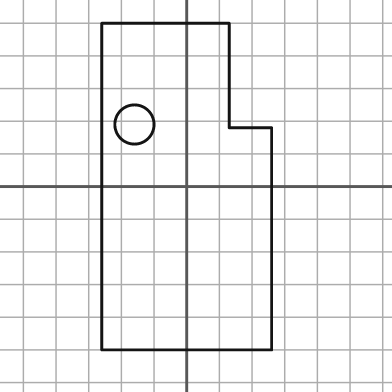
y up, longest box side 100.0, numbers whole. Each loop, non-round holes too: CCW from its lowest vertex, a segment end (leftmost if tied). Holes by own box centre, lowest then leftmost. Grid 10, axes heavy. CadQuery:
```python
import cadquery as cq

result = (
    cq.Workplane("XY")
    .moveTo(-26.0, -50.0)
    .lineTo(26.0, -50.0)
    .lineTo(26.0, 18.0)
    .lineTo(13.0, 18.0)
    .lineTo(13.0, 50.0)
    .lineTo(-26.0, 50.0)
    .close()
    .moveTo(-16.0, 19.0)
    .circle(6.0)
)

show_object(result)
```